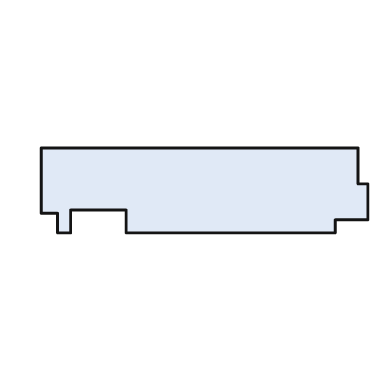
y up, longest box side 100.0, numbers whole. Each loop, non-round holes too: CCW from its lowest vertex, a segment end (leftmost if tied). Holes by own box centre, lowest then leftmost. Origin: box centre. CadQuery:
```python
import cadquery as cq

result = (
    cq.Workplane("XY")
    .moveTo(-45.0, -13.0)
    .lineTo(-41.0, -13.0)
    .lineTo(-41.0, -6.0)
    .lineTo(-24.0, -6.0)
    .lineTo(-24.0, -13.0)
    .lineTo(40.0, -13.0)
    .lineTo(40.0, -9.0)
    .lineTo(50.0, -9.0)
    .lineTo(50.0, 2.0)
    .lineTo(47.0, 2.0)
    .lineTo(47.0, 13.0)
    .lineTo(-50.0, 13.0)
    .lineTo(-50.0, -7.0)
    .lineTo(-45.0, -7.0)
    .close()
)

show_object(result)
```